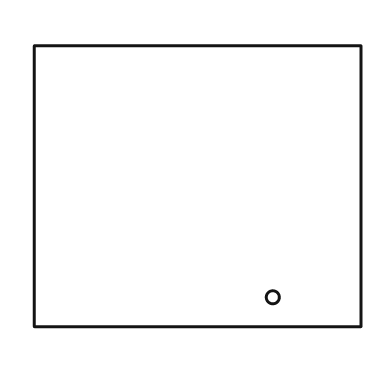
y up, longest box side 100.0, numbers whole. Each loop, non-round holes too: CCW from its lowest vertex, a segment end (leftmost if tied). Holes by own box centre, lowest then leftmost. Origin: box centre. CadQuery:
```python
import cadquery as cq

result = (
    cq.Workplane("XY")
    .moveTo(-50.0, -43.0)
    .lineTo(50.0, -43.0)
    .lineTo(50.0, 43.0)
    .lineTo(-50.0, 43.0)
    .close()
    .moveTo(23.0, -34.0)
    .circle(2.0)
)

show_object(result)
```